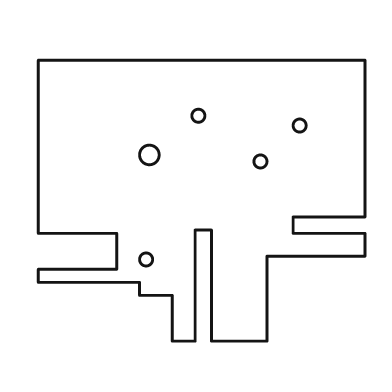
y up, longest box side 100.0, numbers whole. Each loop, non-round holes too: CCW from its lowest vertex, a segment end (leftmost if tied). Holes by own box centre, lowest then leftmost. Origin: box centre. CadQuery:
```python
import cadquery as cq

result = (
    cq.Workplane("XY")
    .moveTo(-9.0, -43.0)
    .lineTo(-2.0, -43.0)
    .lineTo(-2.0, -9.0)
    .lineTo(3.0, -9.0)
    .lineTo(3.0, -43.0)
    .lineTo(20.0, -43.0)
    .lineTo(20.0, -17.0)
    .lineTo(50.0, -17.0)
    .lineTo(50.0, -10.0)
    .lineTo(28.0, -10.0)
    .lineTo(28.0, -5.0)
    .lineTo(50.0, -5.0)
    .lineTo(50.0, 43.0)
    .lineTo(-50.0, 43.0)
    .lineTo(-50.0, -10.0)
    .lineTo(-26.0, -10.0)
    .lineTo(-26.0, -21.0)
    .lineTo(-50.0, -21.0)
    .lineTo(-50.0, -25.0)
    .lineTo(-19.0, -25.0)
    .lineTo(-19.0, -29.0)
    .lineTo(-9.0, -29.0)
    .close()
    .moveTo(-17.0, -18.0)
    .circle(2.0)
    .moveTo(18.0, 12.0)
    .circle(2.0)
    .moveTo(-16.0, 14.0)
    .circle(3.0)
    .moveTo(30.0, 23.0)
    .circle(2.0)
    .moveTo(-1.0, 26.0)
    .circle(2.0)
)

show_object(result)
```